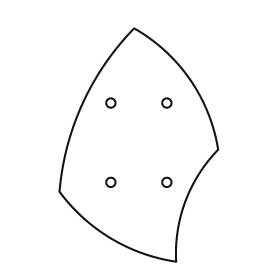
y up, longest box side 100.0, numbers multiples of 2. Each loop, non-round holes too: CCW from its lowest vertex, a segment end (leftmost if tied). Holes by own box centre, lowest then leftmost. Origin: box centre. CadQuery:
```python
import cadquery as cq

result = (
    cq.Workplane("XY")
    .moveTo(16.0, -50.0)
    .threePointArc((20.0, -24.0), (34.0, -2.0))
    .threePointArc((22.0, 28.0), (-2.0, 50.0))
    .threePointArc((-24.0, 18.0), (-34.0, -20.0))
    .threePointArc((-12.0, -40.0), (16.0, -50.0))
    .close()
    .moveTo(-12.0, -16.0)
    .circle(2.0)
    .moveTo(12.0, -16.0)
    .circle(2.0)
    .moveTo(-12.0, 18.0)
    .circle(2.0)
    .moveTo(12.0, 18.0)
    .circle(2.0)
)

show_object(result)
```